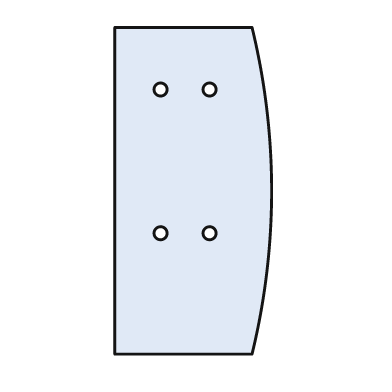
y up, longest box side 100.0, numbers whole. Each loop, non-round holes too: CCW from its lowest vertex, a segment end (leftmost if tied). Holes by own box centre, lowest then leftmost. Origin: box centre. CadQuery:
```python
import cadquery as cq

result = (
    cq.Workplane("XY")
    .moveTo(-24.0, -50.0)
    .lineTo(18.0, -50.0)
    .threePointArc((24.0, 0.0), (18.0, 50.0))
    .lineTo(-24.0, 50.0)
    .close()
    .moveTo(-10.0, -13.0)
    .circle(2.0)
    .moveTo(5.0, -13.0)
    .circle(2.0)
    .moveTo(-10.0, 31.0)
    .circle(2.0)
    .moveTo(5.0, 31.0)
    .circle(2.0)
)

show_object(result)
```